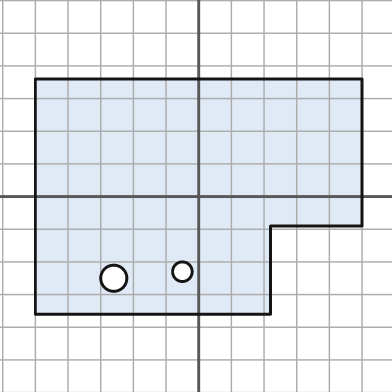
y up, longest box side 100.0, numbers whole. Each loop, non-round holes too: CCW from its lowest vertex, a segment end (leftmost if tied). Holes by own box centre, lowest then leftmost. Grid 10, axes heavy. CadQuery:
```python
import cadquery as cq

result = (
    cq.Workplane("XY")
    .moveTo(-50.0, -36.0)
    .lineTo(22.0, -36.0)
    .lineTo(22.0, -9.0)
    .lineTo(50.0, -9.0)
    .lineTo(50.0, 36.0)
    .lineTo(-50.0, 36.0)
    .close()
    .moveTo(-26.0, -25.0)
    .circle(4.0)
    .moveTo(-5.0, -23.0)
    .circle(3.0)
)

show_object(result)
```